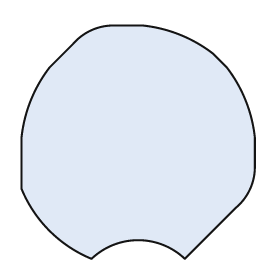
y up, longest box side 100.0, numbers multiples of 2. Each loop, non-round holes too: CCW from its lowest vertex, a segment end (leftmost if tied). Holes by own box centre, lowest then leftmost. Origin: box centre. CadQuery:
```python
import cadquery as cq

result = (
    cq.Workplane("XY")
    .moveTo(-20.0, -50.0)
    .threePointArc((0.0, -42.0), (20.0, -50.0))
    .lineTo(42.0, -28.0)
    .threePointArc((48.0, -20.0), (50.0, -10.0))
    .lineTo(50.0, 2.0)
    .threePointArc((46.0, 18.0), (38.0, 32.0))
    .lineTo(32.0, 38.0)
    .threePointArc((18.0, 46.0), (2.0, 50.0))
    .lineTo(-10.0, 50.0)
    .threePointArc((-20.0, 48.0), (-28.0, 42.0))
    .lineTo(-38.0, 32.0)
    .threePointArc((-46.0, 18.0), (-50.0, 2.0))
    .lineTo(-50.0, -20.0)
    .threePointArc((-38.0, -38.0), (-20.0, -50.0))
    .close()
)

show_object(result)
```